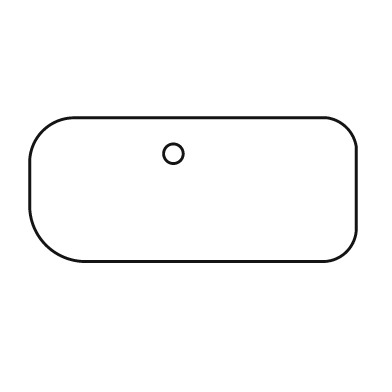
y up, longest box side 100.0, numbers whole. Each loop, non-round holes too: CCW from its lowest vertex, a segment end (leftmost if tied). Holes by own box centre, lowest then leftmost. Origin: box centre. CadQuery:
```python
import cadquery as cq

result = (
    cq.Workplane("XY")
    .moveTo(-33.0, -22.0)
    .lineTo(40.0, -22.0)
    .threePointArc((47.0, -19.0), (50.0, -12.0))
    .lineTo(50.0, 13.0)
    .threePointArc((47.0, 19.0), (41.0, 22.0))
    .lineTo(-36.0, 22.0)
    .threePointArc((-46.0, 18.0), (-50.0, 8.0))
    .lineTo(-50.0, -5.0)
    .threePointArc((-45.0, -17.0), (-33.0, -22.0))
    .close()
    .moveTo(-6.0, 11.0)
    .circle(3.0)
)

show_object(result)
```